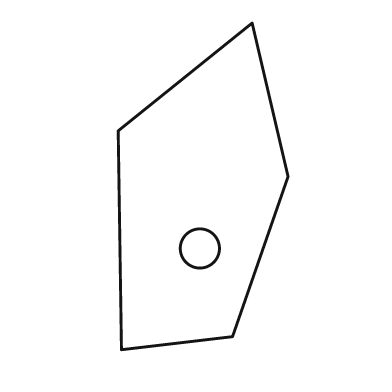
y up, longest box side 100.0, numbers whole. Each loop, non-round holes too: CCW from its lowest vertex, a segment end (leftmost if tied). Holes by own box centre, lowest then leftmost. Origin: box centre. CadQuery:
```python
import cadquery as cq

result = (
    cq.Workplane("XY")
    .moveTo(-25.0, -50.0)
    .lineTo(9.0, -46.0)
    .lineTo(26.0, 3.0)
    .lineTo(15.0, 50.0)
    .lineTo(-26.0, 17.0)
    .close()
    .moveTo(-1.0, -19.0)
    .circle(6.0)
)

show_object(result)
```